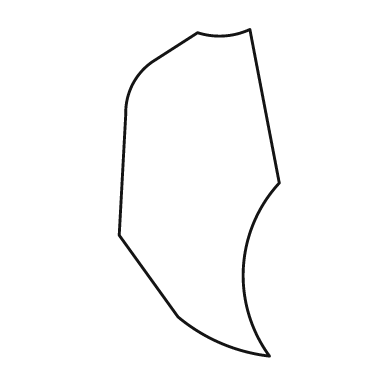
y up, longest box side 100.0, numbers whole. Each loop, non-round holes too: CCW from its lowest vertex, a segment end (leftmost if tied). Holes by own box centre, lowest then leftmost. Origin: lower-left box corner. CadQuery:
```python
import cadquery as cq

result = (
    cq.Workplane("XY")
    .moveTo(46.0, 0.0)
    .threePointArc((38.0, 27.0), (49.0, 53.0))
    .lineTo(40.0, 100.0)
    .threePointArc((32.0, 98.0), (24.0, 99.0))
    .lineTo(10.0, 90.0)
    .threePointArc((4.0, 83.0), (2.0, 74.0))
    .lineTo(0.0, 37.0)
    .lineTo(18.0, 12.0)
    .threePointArc((31.0, 4.0), (46.0, 0.0))
    .close()
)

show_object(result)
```